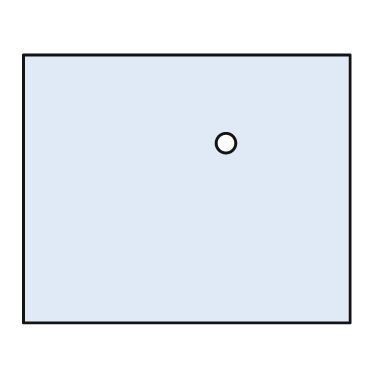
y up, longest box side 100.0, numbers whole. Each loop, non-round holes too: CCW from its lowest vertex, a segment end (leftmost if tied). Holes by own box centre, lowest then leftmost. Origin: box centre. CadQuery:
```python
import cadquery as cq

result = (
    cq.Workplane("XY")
    .moveTo(-50.0, -41.0)
    .lineTo(50.0, -41.0)
    .lineTo(50.0, 41.0)
    .lineTo(-50.0, 41.0)
    .close()
    .moveTo(12.0, 14.0)
    .circle(3.0)
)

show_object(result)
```